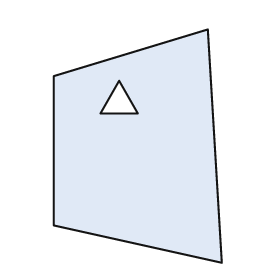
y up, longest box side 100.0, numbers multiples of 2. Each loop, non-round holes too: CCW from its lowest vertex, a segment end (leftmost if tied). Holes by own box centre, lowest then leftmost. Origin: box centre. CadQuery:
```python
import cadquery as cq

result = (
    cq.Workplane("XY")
    .moveTo(36.0, -50.0)
    .lineTo(30.0, 50.0)
    .lineTo(-36.0, 30.0)
    .lineTo(-36.0, -34.0)
    .close()
    .moveTo(-16.0, 14.0)
    .lineTo(0.0, 14.0)
    .lineTo(-8.0, 28.0)
    .close()
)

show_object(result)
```